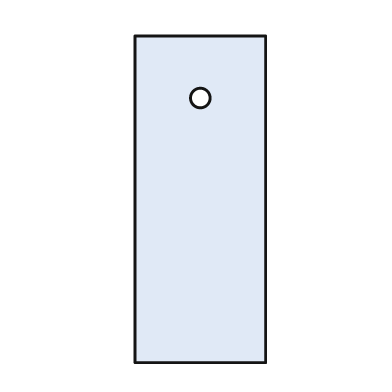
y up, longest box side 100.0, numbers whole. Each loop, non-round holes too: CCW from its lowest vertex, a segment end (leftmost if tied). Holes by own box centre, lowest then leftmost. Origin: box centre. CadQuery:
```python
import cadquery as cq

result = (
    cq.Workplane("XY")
    .moveTo(-20.0, -50.0)
    .lineTo(20.0, -50.0)
    .lineTo(20.0, 50.0)
    .lineTo(-20.0, 50.0)
    .close()
    .moveTo(0.0, 31.0)
    .circle(3.0)
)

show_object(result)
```